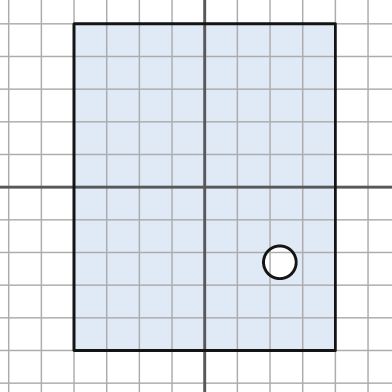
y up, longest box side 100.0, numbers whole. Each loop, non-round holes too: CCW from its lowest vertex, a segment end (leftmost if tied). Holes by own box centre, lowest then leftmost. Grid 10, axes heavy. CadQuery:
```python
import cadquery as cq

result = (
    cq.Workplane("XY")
    .moveTo(-40.0, -50.0)
    .lineTo(40.0, -50.0)
    .lineTo(40.0, 50.0)
    .lineTo(-40.0, 50.0)
    .close()
    .moveTo(23.0, -23.0)
    .circle(5.0)
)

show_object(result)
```